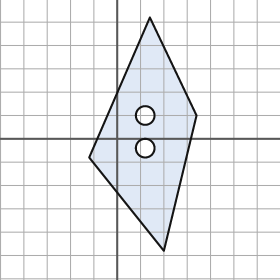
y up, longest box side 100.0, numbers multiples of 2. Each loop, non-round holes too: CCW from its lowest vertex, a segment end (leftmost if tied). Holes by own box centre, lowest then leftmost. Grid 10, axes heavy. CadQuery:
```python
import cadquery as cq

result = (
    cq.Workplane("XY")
    .moveTo(20.0, -48.0)
    .lineTo(34.0, 10.0)
    .lineTo(14.0, 52.0)
    .lineTo(-12.0, -8.0)
    .close()
    .moveTo(12.0, -4.0)
    .circle(4.0)
    .moveTo(12.0, 10.0)
    .circle(4.0)
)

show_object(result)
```